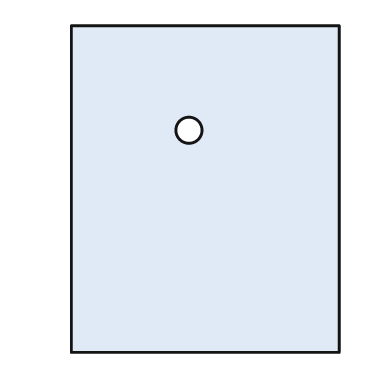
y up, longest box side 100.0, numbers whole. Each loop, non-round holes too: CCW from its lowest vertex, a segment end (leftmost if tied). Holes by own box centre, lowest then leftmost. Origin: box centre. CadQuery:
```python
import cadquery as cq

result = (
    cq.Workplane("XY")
    .moveTo(-41.0, -50.0)
    .lineTo(41.0, -50.0)
    .lineTo(41.0, 50.0)
    .lineTo(-41.0, 50.0)
    .close()
    .moveTo(-5.0, 18.0)
    .circle(4.0)
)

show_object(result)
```